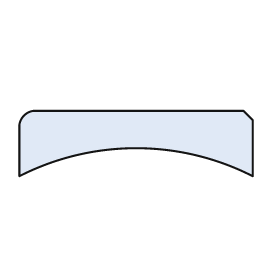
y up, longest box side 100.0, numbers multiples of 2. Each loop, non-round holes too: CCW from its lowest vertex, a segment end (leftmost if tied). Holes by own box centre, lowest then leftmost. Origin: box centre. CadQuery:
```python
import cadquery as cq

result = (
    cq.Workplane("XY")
    .moveTo(-50.0, -14.0)
    .threePointArc((0.0, -2.0), (50.0, -14.0))
    .lineTo(50.0, 10.0)
    .lineTo(46.0, 14.0)
    .lineTo(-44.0, 14.0)
    .threePointArc((-48.0, 12.0), (-50.0, 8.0))
    .close()
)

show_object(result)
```